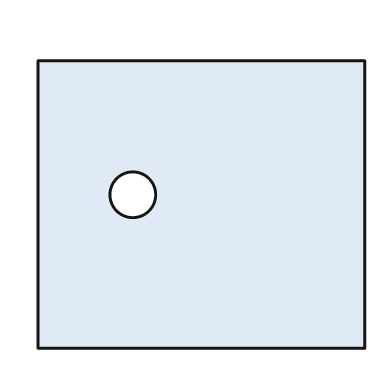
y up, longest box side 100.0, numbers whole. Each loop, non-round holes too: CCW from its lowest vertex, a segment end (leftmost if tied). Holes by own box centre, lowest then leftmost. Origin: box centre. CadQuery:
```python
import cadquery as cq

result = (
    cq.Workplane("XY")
    .moveTo(-50.0, -44.0)
    .lineTo(50.0, -44.0)
    .lineTo(50.0, 44.0)
    .lineTo(-50.0, 44.0)
    .close()
    .moveTo(-21.0, 3.0)
    .circle(7.0)
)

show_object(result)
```